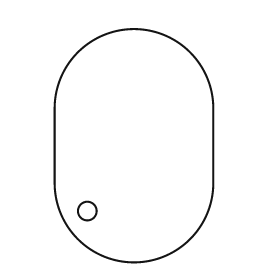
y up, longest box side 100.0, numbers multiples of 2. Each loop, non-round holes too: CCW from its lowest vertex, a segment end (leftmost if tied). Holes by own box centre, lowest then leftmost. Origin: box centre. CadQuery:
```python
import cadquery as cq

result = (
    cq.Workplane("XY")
    .moveTo(-34.0, -16.0)
    .threePointArc((0.0, -50.0), (34.0, -16.0))
    .lineTo(34.0, 16.0)
    .threePointArc((0.0, 50.0), (-34.0, 16.0))
    .close()
    .moveTo(-20.0, -28.0)
    .circle(4.0)
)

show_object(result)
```